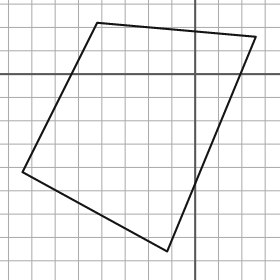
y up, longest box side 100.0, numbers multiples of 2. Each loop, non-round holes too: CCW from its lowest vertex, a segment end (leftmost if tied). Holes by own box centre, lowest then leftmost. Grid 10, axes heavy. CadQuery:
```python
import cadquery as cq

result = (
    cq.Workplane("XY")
    .moveTo(-12.0, -76.0)
    .lineTo(26.0, 16.0)
    .lineTo(-42.0, 22.0)
    .lineTo(-74.0, -42.0)
    .close()
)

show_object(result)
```